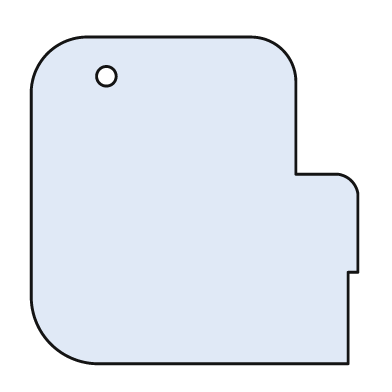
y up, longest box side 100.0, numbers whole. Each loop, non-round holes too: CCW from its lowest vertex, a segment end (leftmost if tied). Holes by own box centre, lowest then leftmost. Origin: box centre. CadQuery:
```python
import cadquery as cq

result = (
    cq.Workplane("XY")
    .moveTo(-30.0, -50.0)
    .lineTo(47.0, -50.0)
    .lineTo(47.0, -22.0)
    .lineTo(50.0, -22.0)
    .lineTo(50.0, 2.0)
    .threePointArc((48.0, 6.0), (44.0, 8.0))
    .lineTo(31.0, 8.0)
    .lineTo(31.0, 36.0)
    .threePointArc((27.0, 46.0), (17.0, 50.0))
    .lineTo(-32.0, 50.0)
    .threePointArc((-45.0, 45.0), (-50.0, 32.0))
    .lineTo(-50.0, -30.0)
    .threePointArc((-44.0, -44.0), (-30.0, -50.0))
    .close()
    .moveTo(-27.0, 38.0)
    .circle(3.0)
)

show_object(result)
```